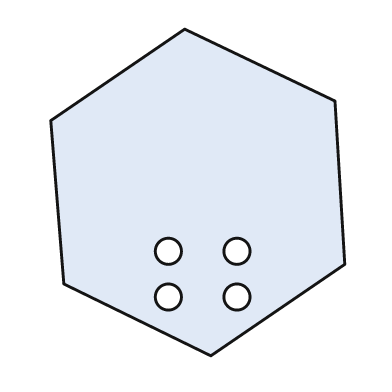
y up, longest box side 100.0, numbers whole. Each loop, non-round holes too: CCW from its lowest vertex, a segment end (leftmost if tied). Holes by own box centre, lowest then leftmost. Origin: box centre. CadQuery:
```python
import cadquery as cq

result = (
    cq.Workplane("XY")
    .moveTo(4.0, -50.0)
    .lineTo(45.0, -22.0)
    .lineTo(42.0, 28.0)
    .lineTo(-4.0, 50.0)
    .lineTo(-45.0, 22.0)
    .lineTo(-41.0, -28.0)
    .close()
    .moveTo(-9.0, -32.0)
    .circle(4.0)
    .moveTo(12.0, -32.0)
    .circle(4.0)
    .moveTo(-9.0, -18.0)
    .circle(4.0)
    .moveTo(12.0, -18.0)
    .circle(4.0)
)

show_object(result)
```